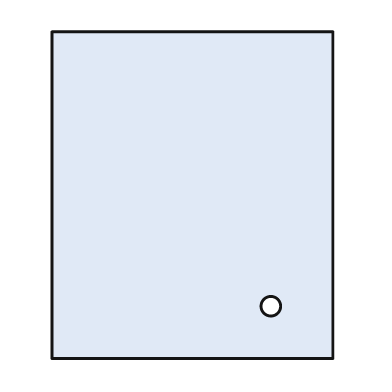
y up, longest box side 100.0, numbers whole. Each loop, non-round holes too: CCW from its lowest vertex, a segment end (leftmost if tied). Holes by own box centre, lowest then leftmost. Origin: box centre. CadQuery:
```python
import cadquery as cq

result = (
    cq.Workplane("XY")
    .moveTo(-43.0, -50.0)
    .lineTo(43.0, -50.0)
    .lineTo(43.0, 50.0)
    .lineTo(-43.0, 50.0)
    .close()
    .moveTo(24.0, -34.0)
    .circle(3.0)
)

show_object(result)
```